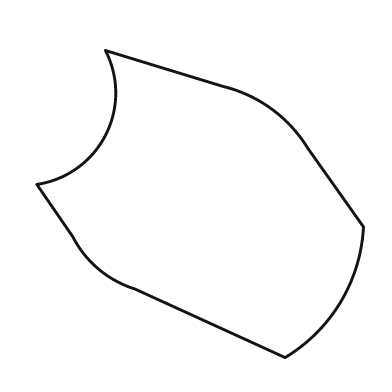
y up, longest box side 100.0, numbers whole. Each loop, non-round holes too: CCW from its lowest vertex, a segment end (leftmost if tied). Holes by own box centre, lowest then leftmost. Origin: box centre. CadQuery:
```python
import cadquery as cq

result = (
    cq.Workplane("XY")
    .moveTo(26.0, -47.0)
    .threePointArc((43.0, -30.0), (50.0, -7.0))
    .lineTo(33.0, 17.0)
    .threePointArc((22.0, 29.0), (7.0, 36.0))
    .lineTo(-29.0, 47.0)
    .threePointArc((-29.0, 21.0), (-50.0, 6.0))
    .lineTo(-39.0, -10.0)
    .threePointArc((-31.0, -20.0), (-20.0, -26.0))
    .close()
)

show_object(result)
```